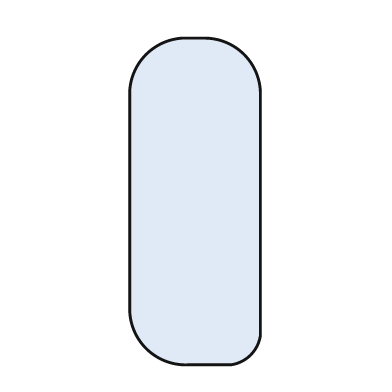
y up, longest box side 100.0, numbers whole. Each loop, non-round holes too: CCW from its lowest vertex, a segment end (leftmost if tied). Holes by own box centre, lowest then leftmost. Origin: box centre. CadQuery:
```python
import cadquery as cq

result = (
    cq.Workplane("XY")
    .moveTo(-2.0, -50.0)
    .lineTo(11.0, -50.0)
    .threePointArc((17.0, -47.0), (20.0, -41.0))
    .lineTo(20.0, 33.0)
    .threePointArc((15.0, 45.0), (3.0, 50.0))
    .lineTo(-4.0, 50.0)
    .threePointArc((-15.0, 45.0), (-20.0, 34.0))
    .lineTo(-20.0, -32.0)
    .threePointArc((-15.0, -45.0), (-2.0, -50.0))
    .close()
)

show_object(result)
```